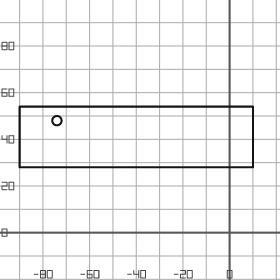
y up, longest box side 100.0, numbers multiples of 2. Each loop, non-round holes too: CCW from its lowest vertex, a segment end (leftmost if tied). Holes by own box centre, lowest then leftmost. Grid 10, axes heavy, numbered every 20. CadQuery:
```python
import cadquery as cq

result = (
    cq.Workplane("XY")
    .moveTo(-90.0, 28.0)
    .lineTo(10.0, 28.0)
    .lineTo(10.0, 54.0)
    .lineTo(-90.0, 54.0)
    .close()
    .moveTo(-74.0, 48.0)
    .circle(2.0)
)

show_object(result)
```